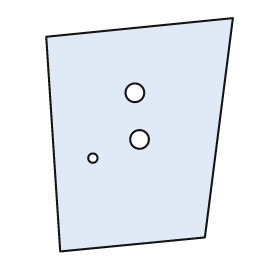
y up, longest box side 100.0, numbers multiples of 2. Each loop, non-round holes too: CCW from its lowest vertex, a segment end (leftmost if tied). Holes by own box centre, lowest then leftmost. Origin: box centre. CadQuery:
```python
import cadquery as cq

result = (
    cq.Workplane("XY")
    .moveTo(-34.0, -50.0)
    .lineTo(28.0, -44.0)
    .lineTo(40.0, 50.0)
    .lineTo(-40.0, 42.0)
    .close()
    .moveTo(-20.0, -10.0)
    .circle(2.0)
    .moveTo(0.0, -2.0)
    .circle(4.0)
    .moveTo(-2.0, 18.0)
    .circle(4.0)
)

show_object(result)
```